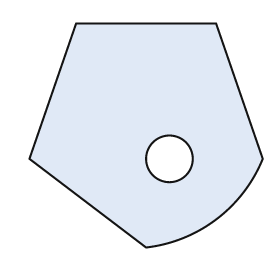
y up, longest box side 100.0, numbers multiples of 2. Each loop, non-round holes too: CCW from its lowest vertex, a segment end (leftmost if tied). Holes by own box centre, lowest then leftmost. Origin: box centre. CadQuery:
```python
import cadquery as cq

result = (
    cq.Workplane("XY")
    .moveTo(0.0, -48.0)
    .threePointArc((30.0, -36.0), (50.0, -10.0))
    .lineTo(30.0, 48.0)
    .lineTo(-30.0, 48.0)
    .lineTo(-50.0, -10.0)
    .close()
    .moveTo(10.0, -10.0)
    .circle(10.0)
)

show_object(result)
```